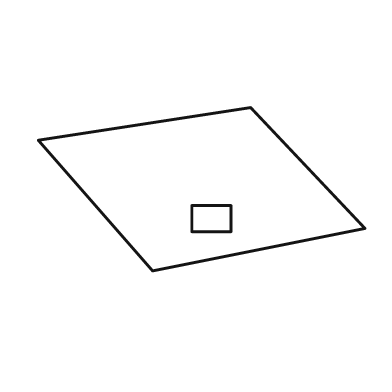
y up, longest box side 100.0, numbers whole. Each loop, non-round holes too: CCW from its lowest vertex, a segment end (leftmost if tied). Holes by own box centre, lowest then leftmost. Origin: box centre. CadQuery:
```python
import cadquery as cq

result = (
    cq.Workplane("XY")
    .moveTo(-15.0, -25.0)
    .lineTo(50.0, -12.0)
    .lineTo(15.0, 25.0)
    .lineTo(-50.0, 15.0)
    .close()
    .moveTo(-3.0, -13.0)
    .lineTo(9.0, -13.0)
    .lineTo(9.0, -5.0)
    .lineTo(-3.0, -5.0)
    .close()
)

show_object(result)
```